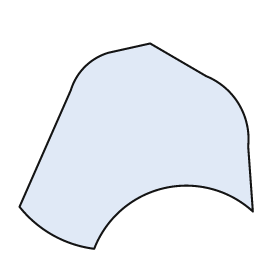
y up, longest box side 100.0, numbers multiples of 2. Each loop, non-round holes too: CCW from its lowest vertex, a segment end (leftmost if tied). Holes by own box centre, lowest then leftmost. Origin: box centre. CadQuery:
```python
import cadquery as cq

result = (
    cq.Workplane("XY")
    .moveTo(-18.0, -44.0)
    .threePointArc((12.0, -18.0), (50.0, -28.0))
    .lineTo(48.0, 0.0)
    .threePointArc((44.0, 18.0), (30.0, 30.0))
    .lineTo(6.0, 44.0)
    .lineTo(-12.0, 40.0)
    .threePointArc((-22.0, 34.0), (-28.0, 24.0))
    .lineTo(-50.0, -26.0)
    .threePointArc((-36.0, -38.0), (-18.0, -44.0))
    .close()
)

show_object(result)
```